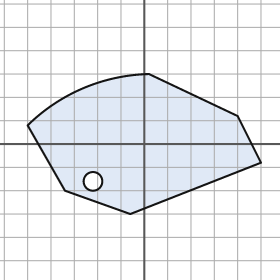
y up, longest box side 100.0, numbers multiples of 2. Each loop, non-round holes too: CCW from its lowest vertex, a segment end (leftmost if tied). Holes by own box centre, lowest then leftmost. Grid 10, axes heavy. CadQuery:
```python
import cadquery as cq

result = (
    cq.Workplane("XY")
    .moveTo(-6.0, -30.0)
    .lineTo(50.0, -8.0)
    .lineTo(40.0, 12.0)
    .lineTo(2.0, 30.0)
    .threePointArc((-26.0, 24.0), (-50.0, 8.0))
    .lineTo(-34.0, -20.0)
    .close()
    .moveTo(-22.0, -16.0)
    .circle(4.0)
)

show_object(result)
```